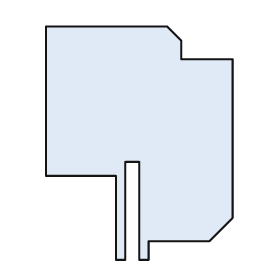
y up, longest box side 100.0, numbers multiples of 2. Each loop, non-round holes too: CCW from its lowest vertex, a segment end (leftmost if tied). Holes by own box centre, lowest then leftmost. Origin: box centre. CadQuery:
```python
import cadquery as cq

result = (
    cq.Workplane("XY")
    .moveTo(-10.0, -50.0)
    .lineTo(-6.0, -50.0)
    .lineTo(-6.0, -8.0)
    .lineTo(0.0, -8.0)
    .lineTo(0.0, -50.0)
    .lineTo(4.0, -50.0)
    .lineTo(4.0, -42.0)
    .lineTo(30.0, -42.0)
    .lineTo(40.0, -32.0)
    .lineTo(40.0, 36.0)
    .lineTo(18.0, 36.0)
    .lineTo(18.0, 44.0)
    .lineTo(12.0, 50.0)
    .lineTo(-40.0, 50.0)
    .lineTo(-40.0, -14.0)
    .lineTo(-10.0, -14.0)
    .close()
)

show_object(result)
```